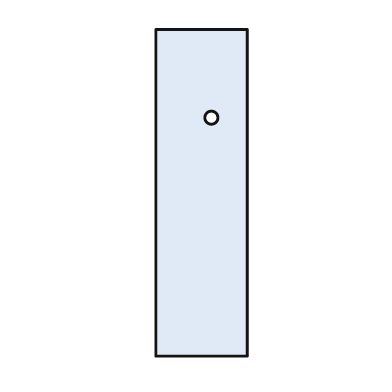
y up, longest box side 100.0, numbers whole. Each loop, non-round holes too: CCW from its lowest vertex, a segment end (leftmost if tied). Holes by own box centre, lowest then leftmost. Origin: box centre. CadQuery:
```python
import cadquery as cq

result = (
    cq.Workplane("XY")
    .moveTo(-14.0, -50.0)
    .lineTo(14.0, -50.0)
    .lineTo(14.0, 50.0)
    .lineTo(-14.0, 50.0)
    .close()
    .moveTo(3.0, 23.0)
    .circle(2.0)
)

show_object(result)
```